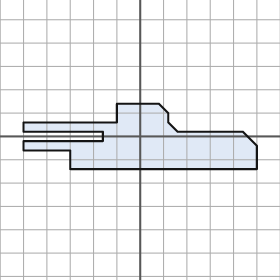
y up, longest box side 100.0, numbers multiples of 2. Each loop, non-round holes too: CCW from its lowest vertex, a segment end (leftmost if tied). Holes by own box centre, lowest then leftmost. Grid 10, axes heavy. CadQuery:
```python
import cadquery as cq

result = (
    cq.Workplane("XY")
    .moveTo(-30.0, -14.0)
    .lineTo(50.0, -14.0)
    .lineTo(50.0, -4.0)
    .lineTo(44.0, 2.0)
    .lineTo(16.0, 2.0)
    .lineTo(12.0, 6.0)
    .lineTo(12.0, 10.0)
    .lineTo(8.0, 14.0)
    .lineTo(-10.0, 14.0)
    .lineTo(-10.0, 6.0)
    .lineTo(-50.0, 6.0)
    .lineTo(-50.0, 2.0)
    .lineTo(-16.0, 2.0)
    .lineTo(-16.0, -2.0)
    .lineTo(-50.0, -2.0)
    .lineTo(-50.0, -6.0)
    .lineTo(-30.0, -6.0)
    .close()
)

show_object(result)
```